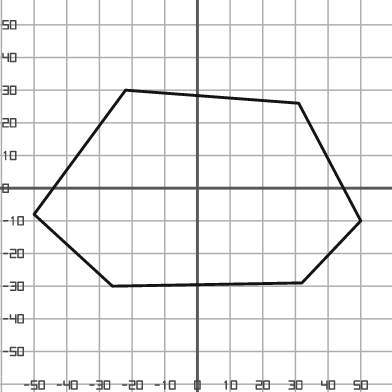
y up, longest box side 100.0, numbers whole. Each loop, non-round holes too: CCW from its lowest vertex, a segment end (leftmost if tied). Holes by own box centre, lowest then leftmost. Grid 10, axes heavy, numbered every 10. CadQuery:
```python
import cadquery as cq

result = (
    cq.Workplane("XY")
    .moveTo(-26.0, -30.0)
    .lineTo(32.0, -29.0)
    .lineTo(50.0, -10.0)
    .lineTo(31.0, 26.0)
    .lineTo(-22.0, 30.0)
    .lineTo(-50.0, -8.0)
    .close()
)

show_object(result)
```